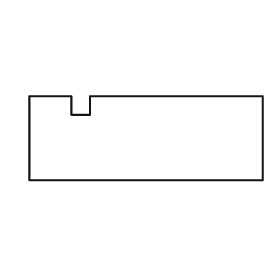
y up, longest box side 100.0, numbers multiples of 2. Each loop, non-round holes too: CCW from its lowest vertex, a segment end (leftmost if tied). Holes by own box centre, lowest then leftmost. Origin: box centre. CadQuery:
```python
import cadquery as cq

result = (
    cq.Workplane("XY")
    .moveTo(-50.0, -18.0)
    .lineTo(50.0, -18.0)
    .lineTo(50.0, 18.0)
    .lineTo(-24.0, 18.0)
    .lineTo(-24.0, 10.0)
    .lineTo(-32.0, 10.0)
    .lineTo(-32.0, 18.0)
    .lineTo(-50.0, 18.0)
    .close()
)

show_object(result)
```